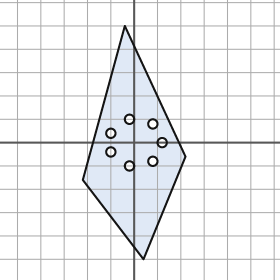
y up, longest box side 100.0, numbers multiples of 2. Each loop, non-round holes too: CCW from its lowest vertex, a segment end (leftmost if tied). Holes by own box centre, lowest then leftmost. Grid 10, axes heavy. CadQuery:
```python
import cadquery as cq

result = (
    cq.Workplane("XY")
    .moveTo(4.0, -50.0)
    .lineTo(22.0, -6.0)
    .lineTo(-4.0, 50.0)
    .lineTo(-22.0, -16.0)
    .close()
    .moveTo(-2.0, -10.0)
    .circle(2.0)
    .moveTo(8.0, -8.0)
    .circle(2.0)
    .moveTo(-10.0, -4.0)
    .circle(2.0)
    .moveTo(12.0, 0.0)
    .circle(2.0)
    .moveTo(-10.0, 4.0)
    .circle(2.0)
    .moveTo(8.0, 8.0)
    .circle(2.0)
    .moveTo(-2.0, 10.0)
    .circle(2.0)
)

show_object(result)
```